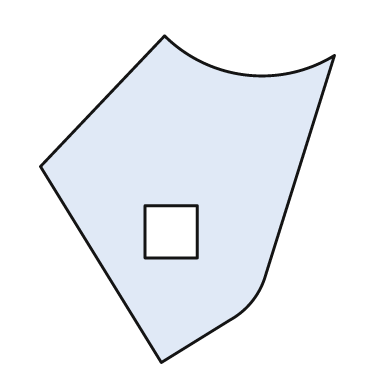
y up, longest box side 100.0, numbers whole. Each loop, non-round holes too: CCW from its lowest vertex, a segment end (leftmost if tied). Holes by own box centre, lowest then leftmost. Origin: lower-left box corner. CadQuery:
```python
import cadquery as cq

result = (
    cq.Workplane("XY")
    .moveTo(37.0, 0.0)
    .lineTo(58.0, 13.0)
    .threePointArc((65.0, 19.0), (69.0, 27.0))
    .lineTo(90.0, 94.0)
    .threePointArc((63.0, 88.0), (38.0, 100.0))
    .lineTo(0.0, 60.0)
    .close()
    .moveTo(32.0, 32.0)
    .lineTo(48.0, 32.0)
    .lineTo(48.0, 48.0)
    .lineTo(32.0, 48.0)
    .close()
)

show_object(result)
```